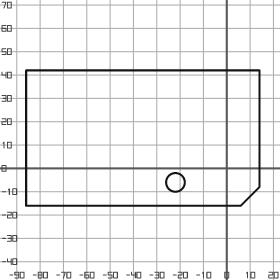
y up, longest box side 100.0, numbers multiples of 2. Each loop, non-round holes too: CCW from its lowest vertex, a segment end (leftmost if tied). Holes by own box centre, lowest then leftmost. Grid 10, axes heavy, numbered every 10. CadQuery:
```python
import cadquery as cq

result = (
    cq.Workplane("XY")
    .moveTo(-86.0, -16.0)
    .lineTo(6.0, -16.0)
    .lineTo(14.0, -8.0)
    .lineTo(14.0, 42.0)
    .lineTo(-86.0, 42.0)
    .close()
    .moveTo(-22.0, -6.0)
    .circle(4.0)
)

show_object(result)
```